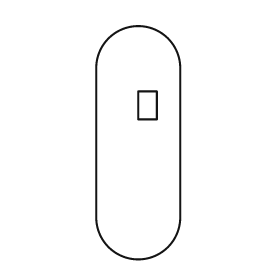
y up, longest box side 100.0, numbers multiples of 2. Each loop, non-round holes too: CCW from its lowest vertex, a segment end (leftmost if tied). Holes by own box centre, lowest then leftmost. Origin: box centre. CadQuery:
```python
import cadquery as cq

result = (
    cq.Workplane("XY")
    .moveTo(-18.0, -32.0)
    .threePointArc((0.0, -50.0), (18.0, -32.0))
    .lineTo(18.0, 32.0)
    .threePointArc((0.0, 50.0), (-18.0, 32.0))
    .close()
    .moveTo(0.0, 10.0)
    .lineTo(8.0, 10.0)
    .lineTo(8.0, 22.0)
    .lineTo(0.0, 22.0)
    .close()
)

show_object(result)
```